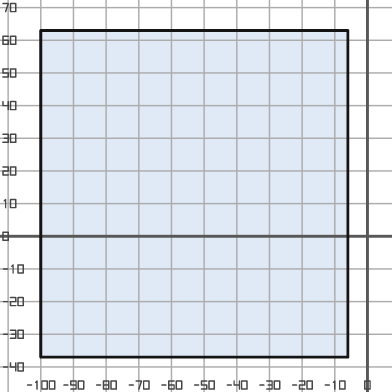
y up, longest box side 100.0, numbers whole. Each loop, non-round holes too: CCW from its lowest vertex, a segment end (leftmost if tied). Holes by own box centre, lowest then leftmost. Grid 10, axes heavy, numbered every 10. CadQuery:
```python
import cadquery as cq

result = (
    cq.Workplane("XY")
    .moveTo(-100.0, -37.0)
    .lineTo(-6.0, -37.0)
    .lineTo(-6.0, 63.0)
    .lineTo(-100.0, 63.0)
    .close()
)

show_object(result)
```